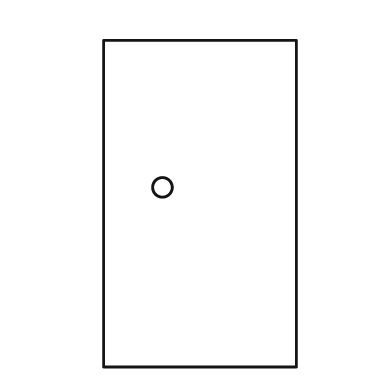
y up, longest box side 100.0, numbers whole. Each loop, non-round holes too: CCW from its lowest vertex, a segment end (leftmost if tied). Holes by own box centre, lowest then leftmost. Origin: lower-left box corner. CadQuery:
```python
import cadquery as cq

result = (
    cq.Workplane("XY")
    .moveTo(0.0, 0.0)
    .lineTo(59.0, 0.0)
    .lineTo(59.0, 100.0)
    .lineTo(0.0, 100.0)
    .close()
    .moveTo(18.0, 55.0)
    .circle(3.0)
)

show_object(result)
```